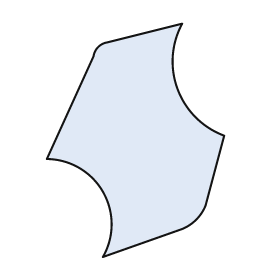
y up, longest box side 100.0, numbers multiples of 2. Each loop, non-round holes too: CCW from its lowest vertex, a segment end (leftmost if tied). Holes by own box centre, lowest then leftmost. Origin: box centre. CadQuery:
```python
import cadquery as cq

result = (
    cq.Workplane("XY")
    .moveTo(-14.0, -50.0)
    .lineTo(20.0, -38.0)
    .threePointArc((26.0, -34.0), (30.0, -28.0))
    .lineTo(38.0, 2.0)
    .threePointArc((18.0, 22.0), (20.0, 50.0))
    .lineTo(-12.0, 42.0)
    .threePointArc((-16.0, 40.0), (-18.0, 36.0))
    .lineTo(-38.0, -8.0)
    .threePointArc((-14.0, -22.0), (-14.0, -50.0))
    .close()
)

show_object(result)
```